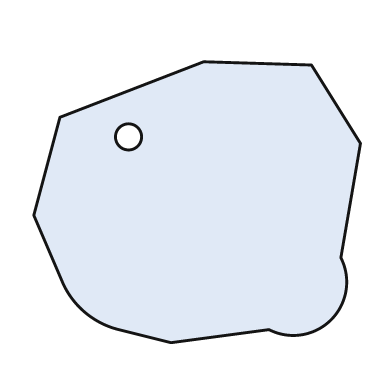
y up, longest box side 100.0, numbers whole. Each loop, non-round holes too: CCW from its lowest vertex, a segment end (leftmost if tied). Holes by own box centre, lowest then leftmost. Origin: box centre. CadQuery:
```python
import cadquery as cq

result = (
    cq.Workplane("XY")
    .moveTo(-8.0, -43.0)
    .lineTo(22.0, -39.0)
    .threePointArc((41.0, -36.0), (44.0, -17.0))
    .lineTo(50.0, 18.0)
    .lineTo(35.0, 42.0)
    .lineTo(2.0, 43.0)
    .lineTo(-42.0, 26.0)
    .lineTo(-50.0, -4.0)
    .lineTo(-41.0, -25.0)
    .threePointArc((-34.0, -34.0), (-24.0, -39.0))
    .close()
    .moveTo(-21.0, 20.0)
    .circle(4.0)
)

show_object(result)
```